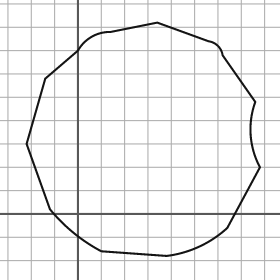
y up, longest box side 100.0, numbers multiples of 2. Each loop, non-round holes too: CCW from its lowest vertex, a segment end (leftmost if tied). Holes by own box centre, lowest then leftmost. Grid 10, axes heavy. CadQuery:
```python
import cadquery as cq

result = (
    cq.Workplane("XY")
    .moveTo(38.0, -18.0)
    .threePointArc((52.0, -14.0), (64.0, -6.0))
    .lineTo(78.0, 20.0)
    .threePointArc((74.0, 34.0), (76.0, 48.0))
    .lineTo(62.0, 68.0)
    .threePointArc((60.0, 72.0), (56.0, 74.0))
    .lineTo(34.0, 82.0)
    .lineTo(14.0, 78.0)
    .threePointArc((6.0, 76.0), (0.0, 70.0))
    .lineTo(-14.0, 58.0)
    .lineTo(-22.0, 30.0)
    .lineTo(-12.0, 2.0)
    .threePointArc((-2.0, -8.0), (10.0, -16.0))
    .close()
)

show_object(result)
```